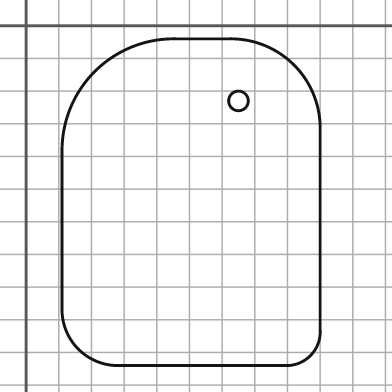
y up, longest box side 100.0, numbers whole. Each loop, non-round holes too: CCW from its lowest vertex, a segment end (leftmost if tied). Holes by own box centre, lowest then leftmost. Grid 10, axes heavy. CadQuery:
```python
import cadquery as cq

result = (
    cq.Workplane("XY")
    .moveTo(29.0, -104.0)
    .lineTo(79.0, -104.0)
    .threePointArc((87.0, -101.0), (90.0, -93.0))
    .lineTo(90.0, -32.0)
    .threePointArc((82.0, -12.0), (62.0, -4.0))
    .lineTo(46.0, -4.0)
    .threePointArc((21.0, -14.0), (11.0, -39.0))
    .lineTo(11.0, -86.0)
    .threePointArc((16.0, -99.0), (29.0, -104.0))
    .close()
    .moveTo(65.0, -23.0)
    .circle(3.0)
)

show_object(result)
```